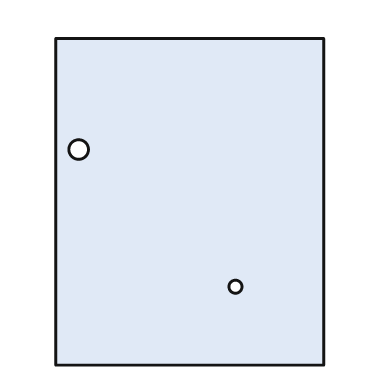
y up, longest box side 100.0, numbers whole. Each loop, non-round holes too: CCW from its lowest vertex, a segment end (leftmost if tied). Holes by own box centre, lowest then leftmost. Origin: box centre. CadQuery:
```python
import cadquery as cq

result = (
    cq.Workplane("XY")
    .moveTo(-41.0, -50.0)
    .lineTo(41.0, -50.0)
    .lineTo(41.0, 50.0)
    .lineTo(-41.0, 50.0)
    .close()
    .moveTo(14.0, -26.0)
    .circle(2.0)
    .moveTo(-34.0, 16.0)
    .circle(3.0)
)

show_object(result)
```